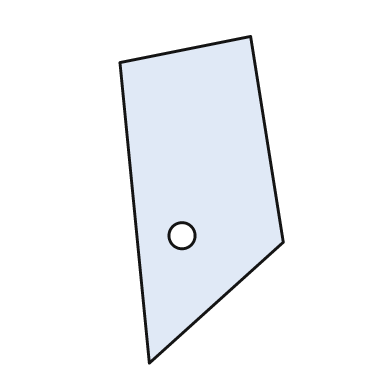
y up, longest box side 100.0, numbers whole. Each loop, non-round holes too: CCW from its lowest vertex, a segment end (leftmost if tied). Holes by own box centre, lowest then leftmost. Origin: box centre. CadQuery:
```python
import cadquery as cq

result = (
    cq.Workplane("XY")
    .moveTo(-16.0, -50.0)
    .lineTo(25.0, -13.0)
    .lineTo(15.0, 50.0)
    .lineTo(-25.0, 42.0)
    .close()
    .moveTo(-6.0, -11.0)
    .circle(4.0)
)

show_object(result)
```